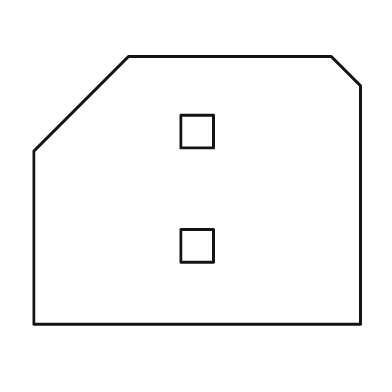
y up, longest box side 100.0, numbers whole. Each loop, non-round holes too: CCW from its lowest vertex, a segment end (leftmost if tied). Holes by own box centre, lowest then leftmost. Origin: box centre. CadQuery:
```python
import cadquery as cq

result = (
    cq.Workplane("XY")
    .moveTo(-50.0, -41.0)
    .lineTo(50.0, -41.0)
    .lineTo(50.0, 32.0)
    .lineTo(41.0, 41.0)
    .lineTo(-21.0, 41.0)
    .lineTo(-50.0, 12.0)
    .close()
    .moveTo(-5.0, -22.0)
    .lineTo(5.0, -22.0)
    .lineTo(5.0, -12.0)
    .lineTo(-5.0, -12.0)
    .close()
    .moveTo(-5.0, 13.0)
    .lineTo(5.0, 13.0)
    .lineTo(5.0, 23.0)
    .lineTo(-5.0, 23.0)
    .close()
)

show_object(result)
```